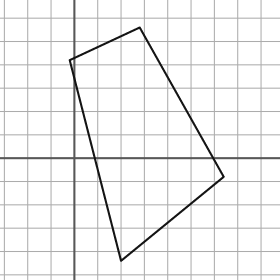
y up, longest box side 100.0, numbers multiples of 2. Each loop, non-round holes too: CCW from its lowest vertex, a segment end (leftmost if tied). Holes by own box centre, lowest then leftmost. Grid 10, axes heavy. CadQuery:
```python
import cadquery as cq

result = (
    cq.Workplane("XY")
    .moveTo(20.0, -44.0)
    .lineTo(64.0, -8.0)
    .lineTo(28.0, 56.0)
    .lineTo(-2.0, 42.0)
    .close()
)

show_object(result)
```